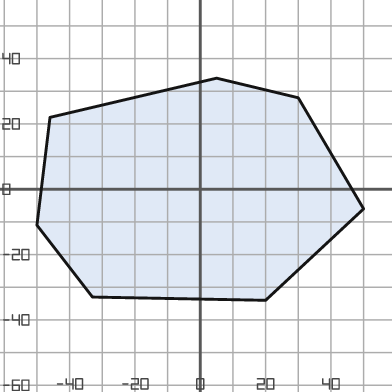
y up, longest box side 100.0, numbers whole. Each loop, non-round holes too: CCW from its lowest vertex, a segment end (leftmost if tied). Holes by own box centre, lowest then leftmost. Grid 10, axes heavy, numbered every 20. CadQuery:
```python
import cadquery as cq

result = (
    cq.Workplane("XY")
    .moveTo(20.0, -34.0)
    .lineTo(50.0, -6.0)
    .lineTo(30.0, 28.0)
    .lineTo(5.0, 34.0)
    .lineTo(-46.0, 22.0)
    .lineTo(-50.0, -11.0)
    .lineTo(-33.0, -33.0)
    .close()
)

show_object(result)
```